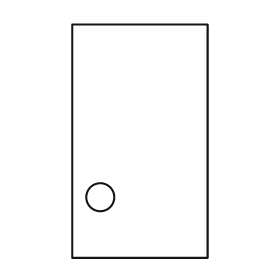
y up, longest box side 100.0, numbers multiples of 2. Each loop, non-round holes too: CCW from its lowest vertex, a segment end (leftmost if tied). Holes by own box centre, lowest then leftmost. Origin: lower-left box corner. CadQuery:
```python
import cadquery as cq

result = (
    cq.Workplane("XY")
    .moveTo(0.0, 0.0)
    .lineTo(58.0, 0.0)
    .lineTo(58.0, 100.0)
    .lineTo(0.0, 100.0)
    .close()
    .moveTo(12.0, 26.0)
    .circle(6.0)
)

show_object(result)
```